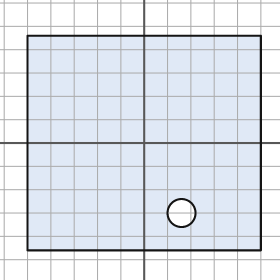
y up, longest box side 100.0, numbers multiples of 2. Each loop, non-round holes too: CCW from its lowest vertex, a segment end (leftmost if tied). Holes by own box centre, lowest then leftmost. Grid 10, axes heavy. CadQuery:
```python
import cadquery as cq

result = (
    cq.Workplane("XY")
    .moveTo(-50.0, -46.0)
    .lineTo(50.0, -46.0)
    .lineTo(50.0, 46.0)
    .lineTo(-50.0, 46.0)
    .close()
    .moveTo(16.0, -30.0)
    .circle(6.0)
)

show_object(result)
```